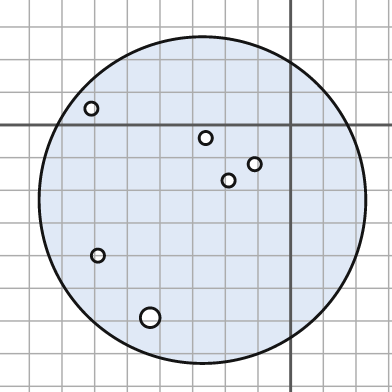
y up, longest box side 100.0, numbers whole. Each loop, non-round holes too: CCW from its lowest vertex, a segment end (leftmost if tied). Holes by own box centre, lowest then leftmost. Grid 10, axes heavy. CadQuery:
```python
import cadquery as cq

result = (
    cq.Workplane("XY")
    .moveTo(-27.0, -23.0)
    .circle(50.0)
    .moveTo(-43.0, -59.0)
    .circle(3.0)
    .moveTo(-59.0, -40.0)
    .circle(2.0)
    .moveTo(-19.0, -17.0)
    .circle(2.0)
    .moveTo(-11.0, -12.0)
    .circle(2.0)
    .moveTo(-26.0, -4.0)
    .circle(2.0)
    .moveTo(-61.0, 5.0)
    .circle(2.0)
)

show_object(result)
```